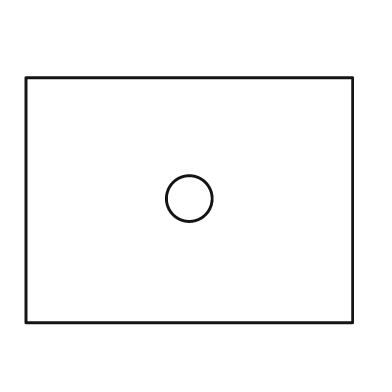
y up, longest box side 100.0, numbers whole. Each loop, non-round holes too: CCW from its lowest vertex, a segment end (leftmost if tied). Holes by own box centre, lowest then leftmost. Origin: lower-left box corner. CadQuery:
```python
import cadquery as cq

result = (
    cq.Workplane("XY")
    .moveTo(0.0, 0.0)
    .lineTo(100.0, 0.0)
    .lineTo(100.0, 75.0)
    .lineTo(0.0, 75.0)
    .close()
    .moveTo(50.0, 38.0)
    .circle(7.0)
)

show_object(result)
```